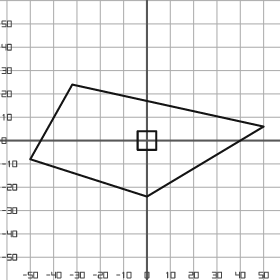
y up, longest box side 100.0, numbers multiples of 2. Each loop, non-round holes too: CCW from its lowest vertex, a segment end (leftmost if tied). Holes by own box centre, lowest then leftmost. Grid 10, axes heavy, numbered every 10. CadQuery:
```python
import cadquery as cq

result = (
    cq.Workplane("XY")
    .moveTo(0.0, -24.0)
    .lineTo(50.0, 6.0)
    .lineTo(-32.0, 24.0)
    .lineTo(-50.0, -8.0)
    .close()
    .moveTo(-4.0, -4.0)
    .lineTo(4.0, -4.0)
    .lineTo(4.0, 4.0)
    .lineTo(-4.0, 4.0)
    .close()
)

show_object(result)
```